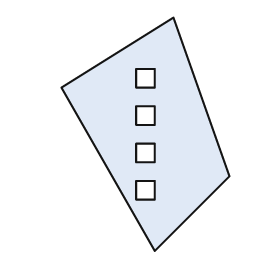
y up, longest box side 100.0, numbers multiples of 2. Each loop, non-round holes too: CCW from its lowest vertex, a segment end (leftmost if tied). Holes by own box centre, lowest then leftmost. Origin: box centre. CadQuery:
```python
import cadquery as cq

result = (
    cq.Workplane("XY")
    .moveTo(4.0, -50.0)
    .lineTo(36.0, -18.0)
    .lineTo(12.0, 50.0)
    .lineTo(-36.0, 20.0)
    .close()
    .moveTo(-4.0, -28.0)
    .lineTo(4.0, -28.0)
    .lineTo(4.0, -20.0)
    .lineTo(-4.0, -20.0)
    .close()
    .moveTo(-4.0, -12.0)
    .lineTo(4.0, -12.0)
    .lineTo(4.0, -4.0)
    .lineTo(-4.0, -4.0)
    .close()
    .moveTo(-4.0, 4.0)
    .lineTo(4.0, 4.0)
    .lineTo(4.0, 12.0)
    .lineTo(-4.0, 12.0)
    .close()
    .moveTo(-4.0, 20.0)
    .lineTo(4.0, 20.0)
    .lineTo(4.0, 28.0)
    .lineTo(-4.0, 28.0)
    .close()
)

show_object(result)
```